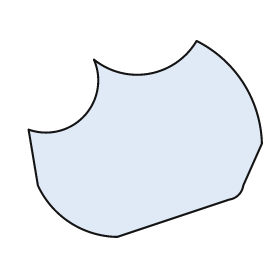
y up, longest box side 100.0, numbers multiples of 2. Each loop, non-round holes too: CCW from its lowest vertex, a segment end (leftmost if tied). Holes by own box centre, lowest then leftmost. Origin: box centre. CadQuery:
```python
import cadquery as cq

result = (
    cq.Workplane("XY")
    .moveTo(-12.0, -42.0)
    .lineTo(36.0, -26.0)
    .threePointArc((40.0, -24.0), (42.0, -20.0))
    .lineTo(50.0, -2.0)
    .threePointArc((42.0, 24.0), (22.0, 42.0))
    .threePointArc((2.0, 28.0), (-22.0, 34.0))
    .threePointArc((-26.0, 10.0), (-50.0, 4.0))
    .lineTo(-46.0, -20.0)
    .threePointArc((-32.0, -36.0), (-12.0, -42.0))
    .close()
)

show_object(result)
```